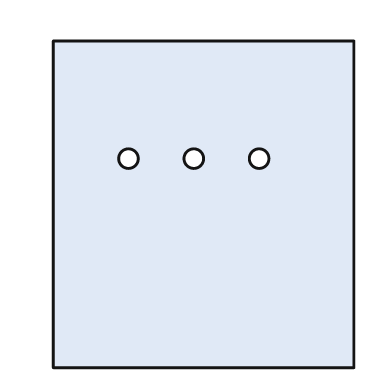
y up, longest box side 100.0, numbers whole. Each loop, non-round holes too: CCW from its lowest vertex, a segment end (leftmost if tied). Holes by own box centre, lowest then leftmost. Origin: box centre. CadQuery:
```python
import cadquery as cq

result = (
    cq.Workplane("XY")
    .moveTo(-46.0, -50.0)
    .lineTo(46.0, -50.0)
    .lineTo(46.0, 50.0)
    .lineTo(-46.0, 50.0)
    .close()
    .moveTo(-23.0, 14.0)
    .circle(3.0)
    .moveTo(-3.0, 14.0)
    .circle(3.0)
    .moveTo(17.0, 14.0)
    .circle(3.0)
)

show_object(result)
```